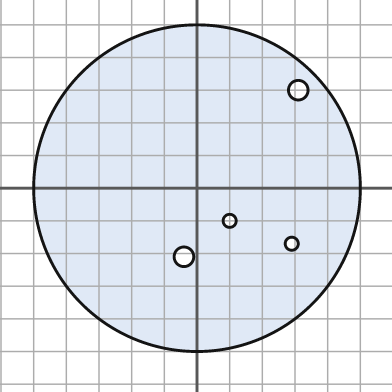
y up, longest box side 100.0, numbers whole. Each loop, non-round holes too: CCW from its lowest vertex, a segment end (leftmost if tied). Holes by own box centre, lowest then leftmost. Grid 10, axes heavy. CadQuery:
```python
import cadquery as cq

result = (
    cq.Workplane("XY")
    .moveTo(0.0, 0.0)
    .circle(50.0)
    .moveTo(-4.0, -21.0)
    .circle(3.0)
    .moveTo(29.0, -17.0)
    .circle(2.0)
    .moveTo(10.0, -10.0)
    .circle(2.0)
    .moveTo(31.0, 30.0)
    .circle(3.0)
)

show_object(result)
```